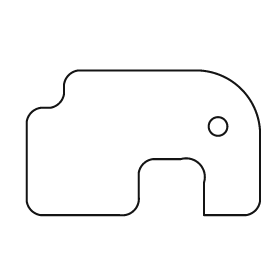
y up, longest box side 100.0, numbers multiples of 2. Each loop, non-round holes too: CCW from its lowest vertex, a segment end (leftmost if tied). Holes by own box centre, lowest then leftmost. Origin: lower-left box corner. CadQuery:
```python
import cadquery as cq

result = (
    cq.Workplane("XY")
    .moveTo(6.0, 0.0)
    .lineTo(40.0, 0.0)
    .threePointArc((46.0, 2.0), (48.0, 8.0))
    .lineTo(48.0, 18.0)
    .threePointArc((50.0, 22.0), (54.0, 24.0))
    .lineTo(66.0, 24.0)
    .threePointArc((74.0, 22.0), (76.0, 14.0))
    .lineTo(76.0, 0.0)
    .lineTo(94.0, 0.0)
    .threePointArc((98.0, 2.0), (100.0, 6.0))
    .lineTo(100.0, 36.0)
    .threePointArc((92.0, 54.0), (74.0, 62.0))
    .lineTo(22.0, 62.0)
    .threePointArc((18.0, 60.0), (16.0, 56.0))
    .lineTo(16.0, 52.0)
    .threePointArc((14.0, 48.0), (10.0, 46.0))
    .lineTo(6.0, 46.0)
    .threePointArc((2.0, 44.0), (0.0, 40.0))
    .lineTo(0.0, 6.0)
    .threePointArc((2.0, 2.0), (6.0, 0.0))
    .close()
    .moveTo(82.0, 38.0)
    .circle(4.0)
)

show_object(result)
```